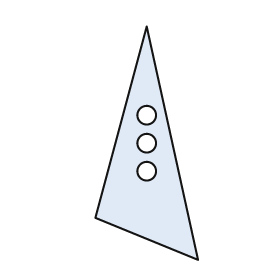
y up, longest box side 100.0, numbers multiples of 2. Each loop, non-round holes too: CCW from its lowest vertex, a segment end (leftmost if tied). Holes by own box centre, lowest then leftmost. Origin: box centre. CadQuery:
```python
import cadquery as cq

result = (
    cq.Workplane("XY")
    .moveTo(22.0, -50.0)
    .lineTo(0.0, 50.0)
    .lineTo(-22.0, -32.0)
    .close()
    .moveTo(0.0, -12.0)
    .circle(4.0)
    .moveTo(0.0, 0.0)
    .circle(4.0)
    .moveTo(0.0, 12.0)
    .circle(4.0)
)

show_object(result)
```